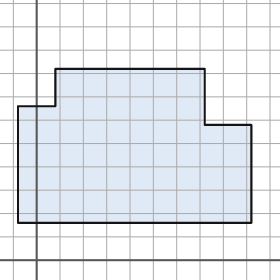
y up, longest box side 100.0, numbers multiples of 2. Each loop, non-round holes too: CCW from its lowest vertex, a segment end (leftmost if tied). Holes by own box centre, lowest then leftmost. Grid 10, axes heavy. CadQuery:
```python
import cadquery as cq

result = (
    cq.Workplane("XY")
    .moveTo(-8.0, 16.0)
    .lineTo(92.0, 16.0)
    .lineTo(92.0, 58.0)
    .lineTo(72.0, 58.0)
    .lineTo(72.0, 82.0)
    .lineTo(8.0, 82.0)
    .lineTo(8.0, 66.0)
    .lineTo(-8.0, 66.0)
    .close()
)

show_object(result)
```